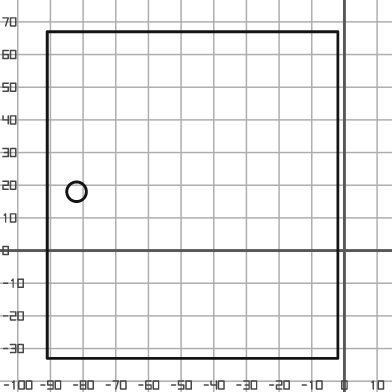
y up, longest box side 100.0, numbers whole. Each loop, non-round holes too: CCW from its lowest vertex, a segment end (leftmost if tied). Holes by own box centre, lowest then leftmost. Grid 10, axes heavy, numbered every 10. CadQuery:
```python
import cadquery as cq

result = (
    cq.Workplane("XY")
    .moveTo(-91.0, -33.0)
    .lineTo(-2.0, -33.0)
    .lineTo(-2.0, 67.0)
    .lineTo(-91.0, 67.0)
    .close()
    .moveTo(-82.0, 18.0)
    .circle(3.0)
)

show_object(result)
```